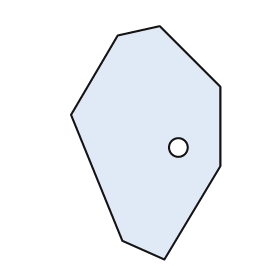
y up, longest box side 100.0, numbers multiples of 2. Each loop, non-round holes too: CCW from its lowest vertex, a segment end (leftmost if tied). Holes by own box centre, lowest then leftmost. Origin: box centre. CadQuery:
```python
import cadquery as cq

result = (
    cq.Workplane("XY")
    .moveTo(8.0, -50.0)
    .lineTo(32.0, -10.0)
    .lineTo(32.0, 24.0)
    .lineTo(6.0, 50.0)
    .lineTo(-12.0, 46.0)
    .lineTo(-32.0, 12.0)
    .lineTo(-10.0, -42.0)
    .close()
    .moveTo(14.0, -2.0)
    .circle(4.0)
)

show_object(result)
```